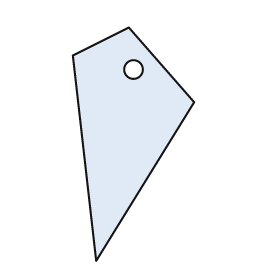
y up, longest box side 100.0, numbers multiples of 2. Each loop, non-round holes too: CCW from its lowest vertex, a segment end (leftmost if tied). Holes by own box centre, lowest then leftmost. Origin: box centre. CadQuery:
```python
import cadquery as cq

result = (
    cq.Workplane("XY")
    .moveTo(-16.0, -50.0)
    .lineTo(26.0, 18.0)
    .lineTo(-2.0, 50.0)
    .lineTo(-26.0, 38.0)
    .close()
    .moveTo(0.0, 32.0)
    .circle(4.0)
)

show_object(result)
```